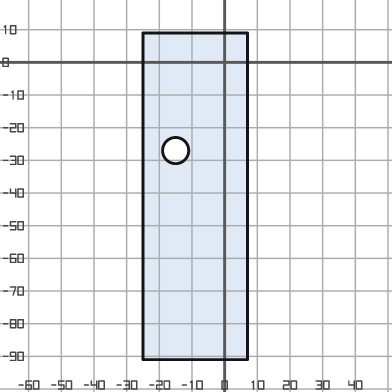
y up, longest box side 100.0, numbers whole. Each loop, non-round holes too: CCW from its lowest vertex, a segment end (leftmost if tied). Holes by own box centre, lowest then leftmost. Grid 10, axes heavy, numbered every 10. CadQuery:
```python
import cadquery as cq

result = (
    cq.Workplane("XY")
    .moveTo(-25.0, -91.0)
    .lineTo(7.0, -91.0)
    .lineTo(7.0, 9.0)
    .lineTo(-25.0, 9.0)
    .close()
    .moveTo(-15.0, -27.0)
    .circle(4.0)
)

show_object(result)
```